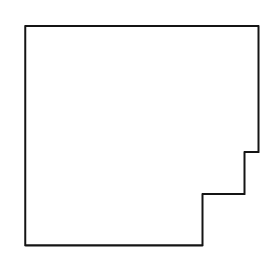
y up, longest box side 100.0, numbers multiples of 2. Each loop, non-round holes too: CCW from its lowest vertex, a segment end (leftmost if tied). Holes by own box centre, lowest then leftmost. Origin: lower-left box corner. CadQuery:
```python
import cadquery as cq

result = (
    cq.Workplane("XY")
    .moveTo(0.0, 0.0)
    .lineTo(76.0, 0.0)
    .lineTo(76.0, 22.0)
    .lineTo(94.0, 22.0)
    .lineTo(94.0, 40.0)
    .lineTo(100.0, 40.0)
    .lineTo(100.0, 94.0)
    .lineTo(0.0, 94.0)
    .close()
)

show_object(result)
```